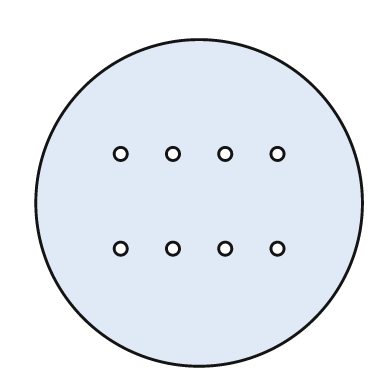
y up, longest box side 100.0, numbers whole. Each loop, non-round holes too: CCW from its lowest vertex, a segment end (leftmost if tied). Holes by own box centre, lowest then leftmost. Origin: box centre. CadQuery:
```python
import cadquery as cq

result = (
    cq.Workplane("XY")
    .moveTo(0.0, 0.0)
    .circle(50.0)
    .moveTo(-24.0, -14.0)
    .circle(2.0)
    .moveTo(-8.0, -14.0)
    .circle(2.0)
    .moveTo(8.0, -14.0)
    .circle(2.0)
    .moveTo(24.0, -14.0)
    .circle(2.0)
    .moveTo(-24.0, 15.0)
    .circle(2.0)
    .moveTo(-8.0, 15.0)
    .circle(2.0)
    .moveTo(8.0, 15.0)
    .circle(2.0)
    .moveTo(24.0, 15.0)
    .circle(2.0)
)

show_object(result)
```